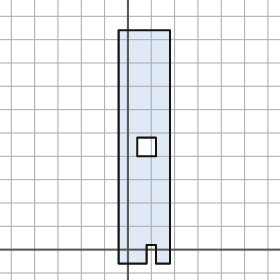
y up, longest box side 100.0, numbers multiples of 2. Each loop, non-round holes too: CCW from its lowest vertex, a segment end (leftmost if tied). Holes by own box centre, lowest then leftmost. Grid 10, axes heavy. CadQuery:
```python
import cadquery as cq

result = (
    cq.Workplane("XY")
    .moveTo(-4.0, -6.0)
    .lineTo(8.0, -6.0)
    .lineTo(8.0, 2.0)
    .lineTo(12.0, 2.0)
    .lineTo(12.0, -6.0)
    .lineTo(18.0, -6.0)
    .lineTo(18.0, 94.0)
    .lineTo(-4.0, 94.0)
    .close()
    .moveTo(4.0, 40.0)
    .lineTo(12.0, 40.0)
    .lineTo(12.0, 48.0)
    .lineTo(4.0, 48.0)
    .close()
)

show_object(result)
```